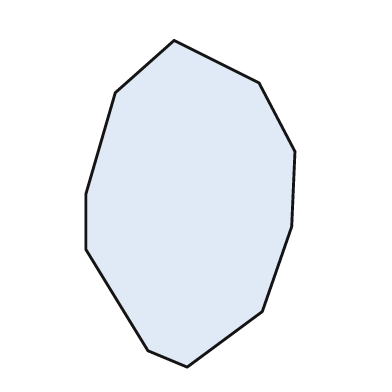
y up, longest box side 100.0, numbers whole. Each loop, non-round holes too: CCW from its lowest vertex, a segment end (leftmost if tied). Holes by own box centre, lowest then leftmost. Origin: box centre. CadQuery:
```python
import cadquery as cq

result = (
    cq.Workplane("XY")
    .moveTo(-1.0, -50.0)
    .lineTo(22.0, -33.0)
    .lineTo(31.0, -7.0)
    .lineTo(32.0, 16.0)
    .lineTo(21.0, 37.0)
    .lineTo(-5.0, 50.0)
    .lineTo(-23.0, 34.0)
    .lineTo(-32.0, 3.0)
    .lineTo(-32.0, -14.0)
    .lineTo(-13.0, -45.0)
    .close()
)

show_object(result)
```